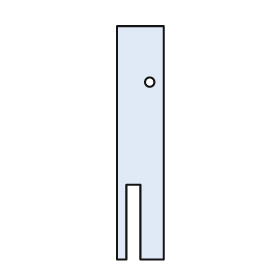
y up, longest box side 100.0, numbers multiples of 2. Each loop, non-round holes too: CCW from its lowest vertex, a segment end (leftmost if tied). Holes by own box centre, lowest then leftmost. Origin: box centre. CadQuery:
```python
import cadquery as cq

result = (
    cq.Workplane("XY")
    .moveTo(-10.0, -50.0)
    .lineTo(-6.0, -50.0)
    .lineTo(-6.0, -18.0)
    .lineTo(0.0, -18.0)
    .lineTo(0.0, -50.0)
    .lineTo(10.0, -50.0)
    .lineTo(10.0, 50.0)
    .lineTo(-10.0, 50.0)
    .close()
    .moveTo(4.0, 26.0)
    .circle(2.0)
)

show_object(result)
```